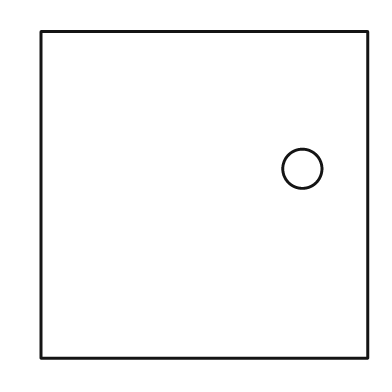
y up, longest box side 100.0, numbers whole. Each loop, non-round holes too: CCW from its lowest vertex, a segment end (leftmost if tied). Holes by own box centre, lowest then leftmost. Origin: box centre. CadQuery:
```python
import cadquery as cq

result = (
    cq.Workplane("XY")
    .moveTo(-50.0, -50.0)
    .lineTo(50.0, -50.0)
    .lineTo(50.0, 50.0)
    .lineTo(-50.0, 50.0)
    .close()
    .moveTo(30.0, 8.0)
    .circle(6.0)
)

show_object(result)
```